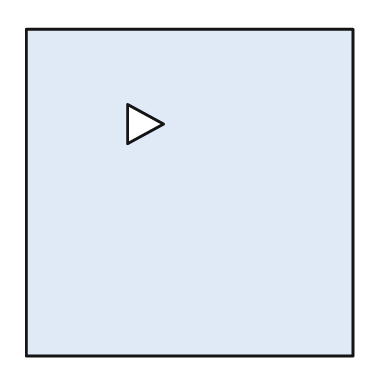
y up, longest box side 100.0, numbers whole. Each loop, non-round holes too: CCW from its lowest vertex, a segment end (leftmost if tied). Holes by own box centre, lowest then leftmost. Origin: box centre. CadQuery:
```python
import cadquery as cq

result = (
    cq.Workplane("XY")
    .moveTo(-50.0, -50.0)
    .lineTo(50.0, -50.0)
    .lineTo(50.0, 50.0)
    .lineTo(-50.0, 50.0)
    .close()
    .moveTo(-19.0, 15.0)
    .lineTo(-8.0, 21.0)
    .lineTo(-19.0, 27.0)
    .close()
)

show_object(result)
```